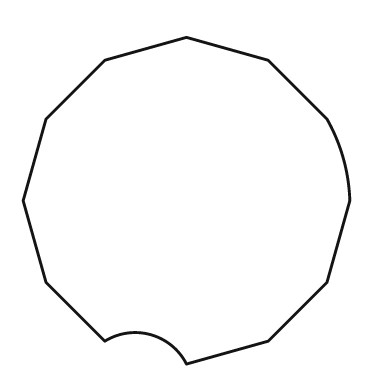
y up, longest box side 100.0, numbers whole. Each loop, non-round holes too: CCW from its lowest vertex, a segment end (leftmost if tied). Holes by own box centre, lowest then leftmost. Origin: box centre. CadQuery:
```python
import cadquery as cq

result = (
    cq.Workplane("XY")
    .moveTo(0.0, -50.0)
    .lineTo(25.0, -43.0)
    .lineTo(43.0, -25.0)
    .lineTo(50.0, 0.0)
    .threePointArc((48.0, 13.0), (43.0, 25.0))
    .lineTo(25.0, 43.0)
    .lineTo(0.0, 50.0)
    .lineTo(-25.0, 43.0)
    .lineTo(-43.0, 25.0)
    .lineTo(-50.0, 0.0)
    .lineTo(-43.0, -25.0)
    .lineTo(-25.0, -43.0)
    .threePointArc((-11.0, -41.0), (0.0, -50.0))
    .close()
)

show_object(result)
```